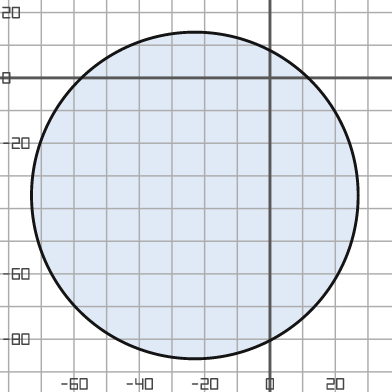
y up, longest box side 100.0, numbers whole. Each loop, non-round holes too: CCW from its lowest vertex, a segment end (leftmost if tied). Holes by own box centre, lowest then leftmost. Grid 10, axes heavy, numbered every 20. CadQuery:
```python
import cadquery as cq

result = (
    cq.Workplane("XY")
    .moveTo(-23.0, -36.0)
    .circle(50.0)
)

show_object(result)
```